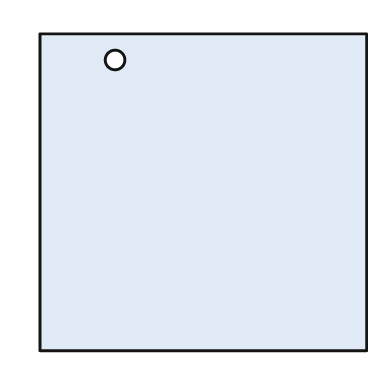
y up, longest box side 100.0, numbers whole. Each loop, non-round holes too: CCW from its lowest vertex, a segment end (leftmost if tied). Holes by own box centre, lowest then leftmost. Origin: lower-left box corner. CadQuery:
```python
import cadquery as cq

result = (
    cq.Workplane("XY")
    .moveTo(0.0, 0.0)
    .lineTo(100.0, 0.0)
    .lineTo(100.0, 97.0)
    .lineTo(0.0, 97.0)
    .close()
    .moveTo(23.0, 89.0)
    .circle(3.0)
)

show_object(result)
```